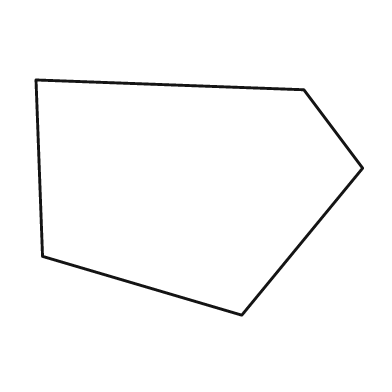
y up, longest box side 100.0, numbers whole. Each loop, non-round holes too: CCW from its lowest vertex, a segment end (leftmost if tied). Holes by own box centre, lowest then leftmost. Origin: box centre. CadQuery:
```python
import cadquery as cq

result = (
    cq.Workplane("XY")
    .moveTo(13.0, -36.0)
    .lineTo(50.0, 9.0)
    .lineTo(32.0, 33.0)
    .lineTo(-50.0, 36.0)
    .lineTo(-48.0, -18.0)
    .close()
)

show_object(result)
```